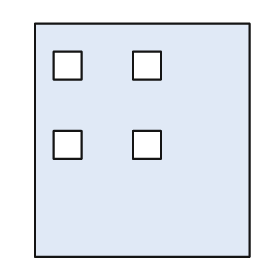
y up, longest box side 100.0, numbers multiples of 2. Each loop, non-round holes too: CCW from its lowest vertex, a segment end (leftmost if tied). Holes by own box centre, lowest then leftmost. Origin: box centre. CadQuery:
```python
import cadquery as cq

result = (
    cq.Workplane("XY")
    .moveTo(-46.0, -50.0)
    .lineTo(46.0, -50.0)
    .lineTo(46.0, 50.0)
    .lineTo(-46.0, 50.0)
    .close()
    .moveTo(-38.0, -8.0)
    .lineTo(-26.0, -8.0)
    .lineTo(-26.0, 4.0)
    .lineTo(-38.0, 4.0)
    .close()
    .moveTo(-4.0, -8.0)
    .lineTo(8.0, -8.0)
    .lineTo(8.0, 4.0)
    .lineTo(-4.0, 4.0)
    .close()
    .moveTo(-38.0, 26.0)
    .lineTo(-26.0, 26.0)
    .lineTo(-26.0, 38.0)
    .lineTo(-38.0, 38.0)
    .close()
    .moveTo(-4.0, 26.0)
    .lineTo(8.0, 26.0)
    .lineTo(8.0, 38.0)
    .lineTo(-4.0, 38.0)
    .close()
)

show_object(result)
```